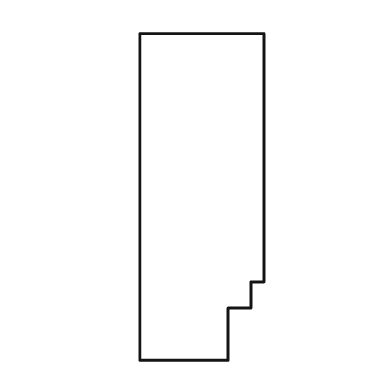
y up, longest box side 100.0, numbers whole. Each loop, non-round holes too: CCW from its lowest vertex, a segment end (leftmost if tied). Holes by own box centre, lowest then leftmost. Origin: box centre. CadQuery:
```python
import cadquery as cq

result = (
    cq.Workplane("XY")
    .moveTo(-19.0, -50.0)
    .lineTo(8.0, -50.0)
    .lineTo(8.0, -34.0)
    .lineTo(15.0, -34.0)
    .lineTo(15.0, -26.0)
    .lineTo(19.0, -26.0)
    .lineTo(19.0, 50.0)
    .lineTo(-19.0, 50.0)
    .close()
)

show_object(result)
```